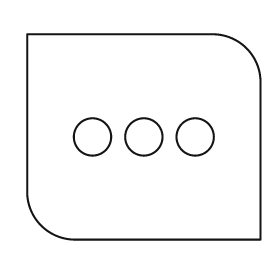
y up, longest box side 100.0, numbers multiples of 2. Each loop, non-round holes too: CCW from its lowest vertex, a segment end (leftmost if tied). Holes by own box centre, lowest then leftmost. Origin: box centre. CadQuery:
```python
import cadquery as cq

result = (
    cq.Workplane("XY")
    .moveTo(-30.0, -44.0)
    .lineTo(50.0, -44.0)
    .lineTo(50.0, 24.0)
    .threePointArc((44.0, 38.0), (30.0, 44.0))
    .lineTo(-50.0, 44.0)
    .lineTo(-50.0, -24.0)
    .threePointArc((-44.0, -38.0), (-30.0, -44.0))
    .close()
    .moveTo(-22.0, 0.0)
    .circle(8.0)
    .moveTo(0.0, 0.0)
    .circle(8.0)
    .moveTo(22.0, 0.0)
    .circle(8.0)
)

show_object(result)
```